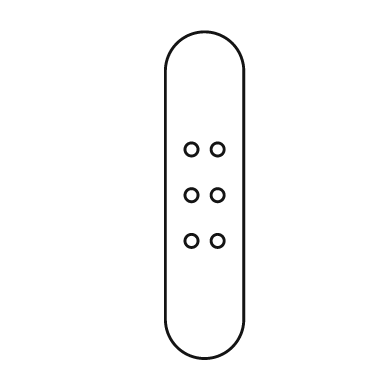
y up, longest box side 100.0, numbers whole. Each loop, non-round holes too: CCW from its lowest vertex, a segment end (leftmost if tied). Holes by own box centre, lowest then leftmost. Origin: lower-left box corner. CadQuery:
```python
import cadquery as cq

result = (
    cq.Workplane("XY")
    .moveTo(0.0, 12.0)
    .threePointArc((12.0, 0.0), (24.0, 12.0))
    .lineTo(24.0, 88.0)
    .threePointArc((12.0, 100.0), (0.0, 88.0))
    .close()
    .moveTo(8.0, 36.0)
    .circle(2.0)
    .moveTo(16.0, 36.0)
    .circle(2.0)
    .moveTo(8.0, 50.0)
    .circle(2.0)
    .moveTo(16.0, 50.0)
    .circle(2.0)
    .moveTo(8.0, 64.0)
    .circle(2.0)
    .moveTo(16.0, 64.0)
    .circle(2.0)
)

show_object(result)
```